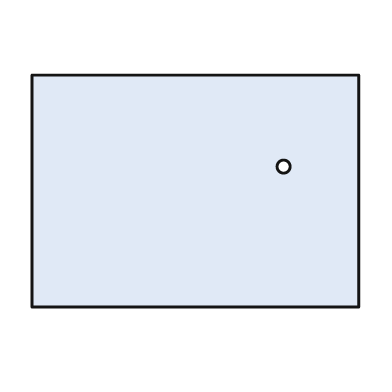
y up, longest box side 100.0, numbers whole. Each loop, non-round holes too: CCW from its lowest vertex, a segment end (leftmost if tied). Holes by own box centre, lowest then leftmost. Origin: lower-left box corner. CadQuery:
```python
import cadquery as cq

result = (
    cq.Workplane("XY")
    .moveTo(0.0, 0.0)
    .lineTo(100.0, 0.0)
    .lineTo(100.0, 71.0)
    .lineTo(0.0, 71.0)
    .close()
    .moveTo(77.0, 43.0)
    .circle(2.0)
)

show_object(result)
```